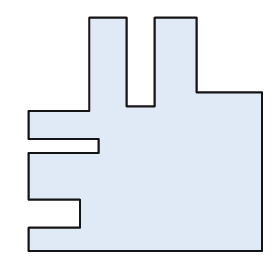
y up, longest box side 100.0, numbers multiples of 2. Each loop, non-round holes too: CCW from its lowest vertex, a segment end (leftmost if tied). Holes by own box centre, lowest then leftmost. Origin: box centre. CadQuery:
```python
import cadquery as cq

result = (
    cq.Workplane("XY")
    .moveTo(-50.0, -50.0)
    .lineTo(50.0, -50.0)
    .lineTo(50.0, 18.0)
    .lineTo(22.0, 18.0)
    .lineTo(22.0, 50.0)
    .lineTo(4.0, 50.0)
    .lineTo(4.0, 12.0)
    .lineTo(-8.0, 12.0)
    .lineTo(-8.0, 50.0)
    .lineTo(-24.0, 50.0)
    .lineTo(-24.0, 10.0)
    .lineTo(-50.0, 10.0)
    .lineTo(-50.0, -2.0)
    .lineTo(-20.0, -2.0)
    .lineTo(-20.0, -8.0)
    .lineTo(-50.0, -8.0)
    .lineTo(-50.0, -28.0)
    .lineTo(-28.0, -28.0)
    .lineTo(-28.0, -40.0)
    .lineTo(-50.0, -40.0)
    .close()
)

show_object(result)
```